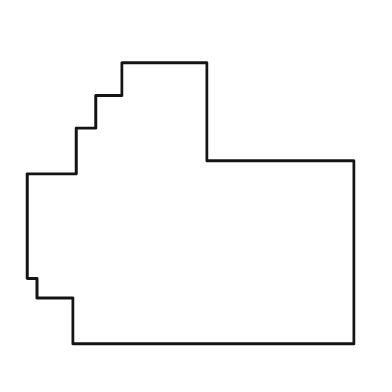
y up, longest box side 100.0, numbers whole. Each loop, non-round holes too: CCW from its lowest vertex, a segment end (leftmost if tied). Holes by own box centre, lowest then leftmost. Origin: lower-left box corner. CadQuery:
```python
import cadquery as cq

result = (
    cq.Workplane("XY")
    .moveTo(14.0, 0.0)
    .lineTo(100.0, 0.0)
    .lineTo(100.0, 56.0)
    .lineTo(55.0, 56.0)
    .lineTo(55.0, 86.0)
    .lineTo(29.0, 86.0)
    .lineTo(29.0, 76.0)
    .lineTo(21.0, 76.0)
    .lineTo(21.0, 66.0)
    .lineTo(15.0, 66.0)
    .lineTo(15.0, 52.0)
    .lineTo(0.0, 52.0)
    .lineTo(0.0, 20.0)
    .lineTo(3.0, 20.0)
    .lineTo(3.0, 14.0)
    .lineTo(14.0, 14.0)
    .close()
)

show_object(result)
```